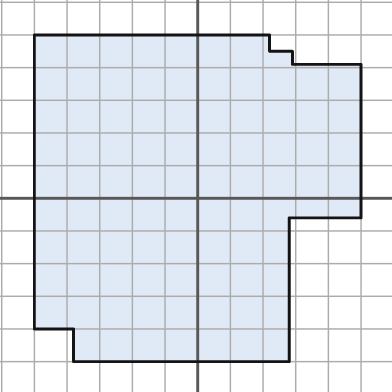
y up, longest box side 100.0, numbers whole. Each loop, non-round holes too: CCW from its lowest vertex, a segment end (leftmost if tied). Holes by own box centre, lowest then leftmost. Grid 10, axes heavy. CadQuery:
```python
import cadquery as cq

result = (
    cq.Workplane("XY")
    .moveTo(-38.0, -50.0)
    .lineTo(28.0, -50.0)
    .lineTo(28.0, -6.0)
    .lineTo(50.0, -6.0)
    .lineTo(50.0, 41.0)
    .lineTo(29.0, 41.0)
    .lineTo(29.0, 45.0)
    .lineTo(22.0, 45.0)
    .lineTo(22.0, 50.0)
    .lineTo(-50.0, 50.0)
    .lineTo(-50.0, -40.0)
    .lineTo(-38.0, -40.0)
    .close()
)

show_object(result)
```